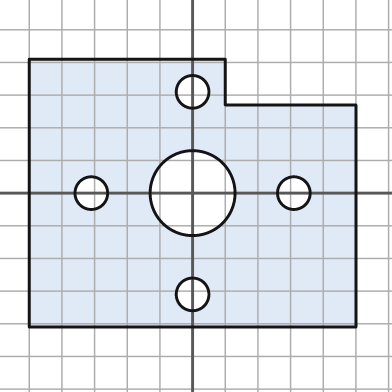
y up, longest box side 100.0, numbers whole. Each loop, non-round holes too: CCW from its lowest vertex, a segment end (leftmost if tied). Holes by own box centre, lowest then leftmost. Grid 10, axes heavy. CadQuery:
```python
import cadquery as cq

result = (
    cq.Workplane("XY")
    .moveTo(-50.0, -41.0)
    .lineTo(50.0, -41.0)
    .lineTo(50.0, 27.0)
    .lineTo(10.0, 27.0)
    .lineTo(10.0, 41.0)
    .lineTo(-50.0, 41.0)
    .close()
    .moveTo(0.0, -31.0)
    .circle(5.0)
    .moveTo(-31.0, 0.0)
    .circle(5.0)
    .moveTo(0.0, 0.0)
    .circle(13.0)
    .moveTo(31.0, 0.0)
    .circle(5.0)
    .moveTo(0.0, 31.0)
    .circle(5.0)
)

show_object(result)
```